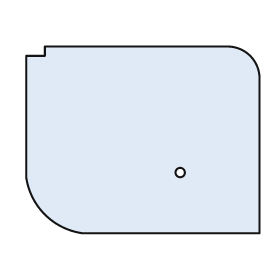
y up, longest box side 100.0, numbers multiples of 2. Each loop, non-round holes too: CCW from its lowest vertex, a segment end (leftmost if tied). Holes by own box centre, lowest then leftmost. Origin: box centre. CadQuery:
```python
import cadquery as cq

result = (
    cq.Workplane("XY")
    .moveTo(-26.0, -40.0)
    .lineTo(50.0, -40.0)
    .lineTo(50.0, 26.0)
    .threePointArc((46.0, 36.0), (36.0, 40.0))
    .lineTo(-42.0, 40.0)
    .lineTo(-42.0, 36.0)
    .lineTo(-50.0, 36.0)
    .lineTo(-50.0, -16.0)
    .threePointArc((-42.0, -32.0), (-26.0, -40.0))
    .close()
    .moveTo(16.0, -14.0)
    .circle(2.0)
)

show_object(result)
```